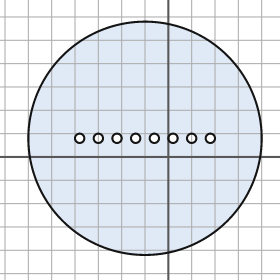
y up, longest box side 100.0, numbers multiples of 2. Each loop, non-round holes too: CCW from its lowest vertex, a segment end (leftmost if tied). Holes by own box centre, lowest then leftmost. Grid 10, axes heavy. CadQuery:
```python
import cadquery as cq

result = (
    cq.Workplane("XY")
    .moveTo(-10.0, 8.0)
    .circle(50.0)
    .moveTo(-38.0, 8.0)
    .circle(2.0)
    .moveTo(-30.0, 8.0)
    .circle(2.0)
    .moveTo(-22.0, 8.0)
    .circle(2.0)
    .moveTo(-14.0, 8.0)
    .circle(2.0)
    .moveTo(-6.0, 8.0)
    .circle(2.0)
    .moveTo(2.0, 8.0)
    .circle(2.0)
    .moveTo(10.0, 8.0)
    .circle(2.0)
    .moveTo(18.0, 8.0)
    .circle(2.0)
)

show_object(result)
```